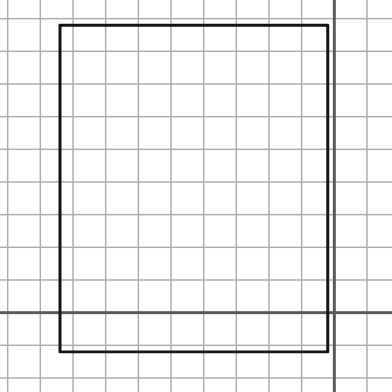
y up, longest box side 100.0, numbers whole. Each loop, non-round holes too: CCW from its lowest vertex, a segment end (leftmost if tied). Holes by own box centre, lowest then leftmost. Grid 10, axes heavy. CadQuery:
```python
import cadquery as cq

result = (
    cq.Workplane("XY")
    .moveTo(-84.0, -12.0)
    .lineTo(-2.0, -12.0)
    .lineTo(-2.0, 88.0)
    .lineTo(-84.0, 88.0)
    .close()
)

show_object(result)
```